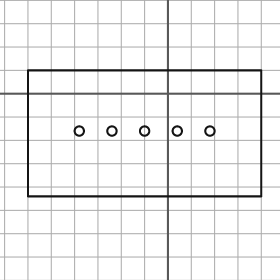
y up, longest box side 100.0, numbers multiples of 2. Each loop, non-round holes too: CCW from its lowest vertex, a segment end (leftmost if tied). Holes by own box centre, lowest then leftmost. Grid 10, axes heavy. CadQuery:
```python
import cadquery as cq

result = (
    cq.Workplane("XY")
    .moveTo(-60.0, -44.0)
    .lineTo(40.0, -44.0)
    .lineTo(40.0, 10.0)
    .lineTo(-60.0, 10.0)
    .close()
    .moveTo(-38.0, -16.0)
    .circle(2.0)
    .moveTo(-24.0, -16.0)
    .circle(2.0)
    .moveTo(-10.0, -16.0)
    .circle(2.0)
    .moveTo(4.0, -16.0)
    .circle(2.0)
    .moveTo(18.0, -16.0)
    .circle(2.0)
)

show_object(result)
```